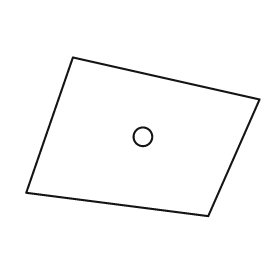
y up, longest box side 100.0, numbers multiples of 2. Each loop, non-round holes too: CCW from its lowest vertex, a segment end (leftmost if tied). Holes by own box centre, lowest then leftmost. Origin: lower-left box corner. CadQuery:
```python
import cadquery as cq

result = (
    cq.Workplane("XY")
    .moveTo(78.0, 0.0)
    .lineTo(100.0, 50.0)
    .lineTo(20.0, 68.0)
    .lineTo(0.0, 10.0)
    .close()
    .moveTo(50.0, 34.0)
    .circle(4.0)
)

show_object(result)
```